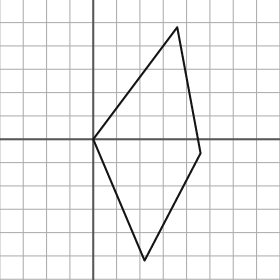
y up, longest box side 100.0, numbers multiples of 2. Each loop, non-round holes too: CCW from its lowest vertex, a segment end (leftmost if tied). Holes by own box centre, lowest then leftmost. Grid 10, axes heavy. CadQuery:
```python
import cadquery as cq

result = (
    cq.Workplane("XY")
    .moveTo(22.0, -52.0)
    .lineTo(46.0, -6.0)
    .lineTo(36.0, 48.0)
    .lineTo(0.0, 0.0)
    .close()
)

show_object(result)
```